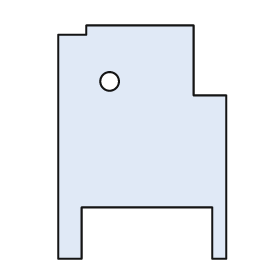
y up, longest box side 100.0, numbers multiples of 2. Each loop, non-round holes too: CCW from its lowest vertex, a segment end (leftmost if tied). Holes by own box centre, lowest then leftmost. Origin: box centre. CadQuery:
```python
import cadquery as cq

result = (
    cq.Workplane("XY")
    .moveTo(-36.0, -50.0)
    .lineTo(-26.0, -50.0)
    .lineTo(-26.0, -28.0)
    .lineTo(30.0, -28.0)
    .lineTo(30.0, -50.0)
    .lineTo(36.0, -50.0)
    .lineTo(36.0, 20.0)
    .lineTo(22.0, 20.0)
    .lineTo(22.0, 50.0)
    .lineTo(-24.0, 50.0)
    .lineTo(-24.0, 46.0)
    .lineTo(-36.0, 46.0)
    .close()
    .moveTo(-14.0, 26.0)
    .circle(4.0)
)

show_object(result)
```